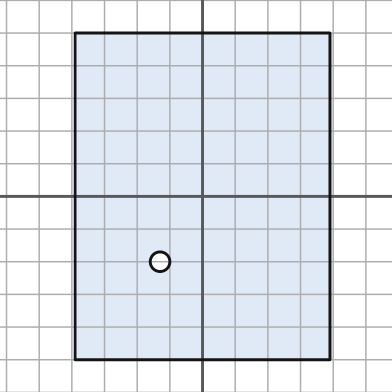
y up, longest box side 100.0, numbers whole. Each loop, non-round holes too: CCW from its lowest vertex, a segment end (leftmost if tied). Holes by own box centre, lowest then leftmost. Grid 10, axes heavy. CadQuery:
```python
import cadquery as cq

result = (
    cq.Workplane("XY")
    .moveTo(-39.0, -50.0)
    .lineTo(39.0, -50.0)
    .lineTo(39.0, 50.0)
    .lineTo(-39.0, 50.0)
    .close()
    .moveTo(-13.0, -20.0)
    .circle(3.0)
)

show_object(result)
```